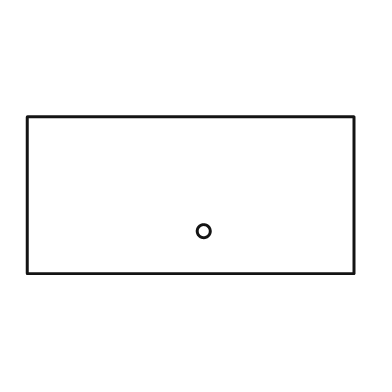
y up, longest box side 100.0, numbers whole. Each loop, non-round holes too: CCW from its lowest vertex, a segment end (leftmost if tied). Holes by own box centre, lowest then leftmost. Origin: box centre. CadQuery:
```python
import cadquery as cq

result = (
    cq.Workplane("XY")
    .moveTo(-50.0, -24.0)
    .lineTo(50.0, -24.0)
    .lineTo(50.0, 24.0)
    .lineTo(-50.0, 24.0)
    .close()
    .moveTo(4.0, -11.0)
    .circle(2.0)
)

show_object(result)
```